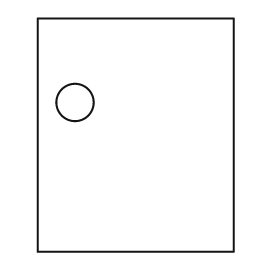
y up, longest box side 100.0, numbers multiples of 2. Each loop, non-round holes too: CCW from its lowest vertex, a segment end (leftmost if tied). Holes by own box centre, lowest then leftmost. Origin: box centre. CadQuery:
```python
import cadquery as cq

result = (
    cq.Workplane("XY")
    .moveTo(-42.0, -50.0)
    .lineTo(42.0, -50.0)
    .lineTo(42.0, 50.0)
    .lineTo(-42.0, 50.0)
    .close()
    .moveTo(-26.0, 14.0)
    .circle(8.0)
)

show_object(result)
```